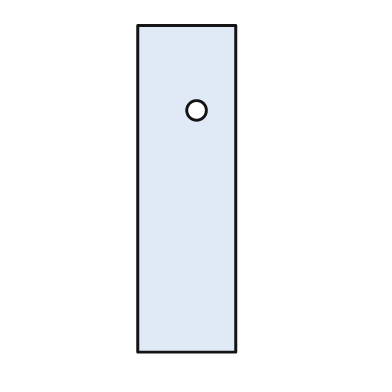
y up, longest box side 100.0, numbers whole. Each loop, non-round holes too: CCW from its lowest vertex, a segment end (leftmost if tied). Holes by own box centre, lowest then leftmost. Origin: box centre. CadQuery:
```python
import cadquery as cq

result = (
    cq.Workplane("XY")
    .moveTo(-15.0, -50.0)
    .lineTo(15.0, -50.0)
    .lineTo(15.0, 50.0)
    .lineTo(-15.0, 50.0)
    .close()
    .moveTo(3.0, 24.0)
    .circle(3.0)
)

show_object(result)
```